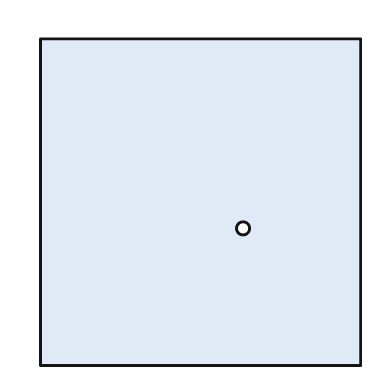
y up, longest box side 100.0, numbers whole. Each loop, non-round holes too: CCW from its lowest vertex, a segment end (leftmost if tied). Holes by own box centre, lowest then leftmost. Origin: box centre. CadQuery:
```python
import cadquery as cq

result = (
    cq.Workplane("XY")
    .moveTo(-49.0, -50.0)
    .lineTo(49.0, -50.0)
    .lineTo(49.0, 50.0)
    .lineTo(-49.0, 50.0)
    .close()
    .moveTo(13.0, -8.0)
    .circle(2.0)
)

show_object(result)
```